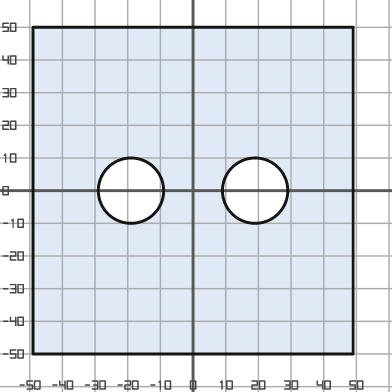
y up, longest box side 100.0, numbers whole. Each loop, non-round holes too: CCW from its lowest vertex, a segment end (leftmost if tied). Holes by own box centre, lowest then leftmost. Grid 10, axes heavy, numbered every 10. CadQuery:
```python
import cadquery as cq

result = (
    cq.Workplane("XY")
    .moveTo(-49.0, -50.0)
    .lineTo(49.0, -50.0)
    .lineTo(49.0, 50.0)
    .lineTo(-49.0, 50.0)
    .close()
    .moveTo(-19.0, 0.0)
    .circle(10.0)
    .moveTo(19.0, 0.0)
    .circle(10.0)
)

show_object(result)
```